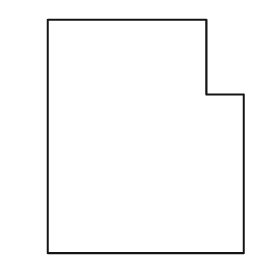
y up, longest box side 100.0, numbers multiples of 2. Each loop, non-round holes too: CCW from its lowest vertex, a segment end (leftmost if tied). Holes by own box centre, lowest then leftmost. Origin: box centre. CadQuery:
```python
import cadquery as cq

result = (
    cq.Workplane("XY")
    .moveTo(-42.0, -50.0)
    .lineTo(42.0, -50.0)
    .lineTo(42.0, 18.0)
    .lineTo(26.0, 18.0)
    .lineTo(26.0, 50.0)
    .lineTo(-42.0, 50.0)
    .close()
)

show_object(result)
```